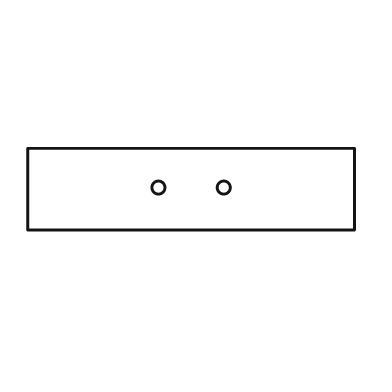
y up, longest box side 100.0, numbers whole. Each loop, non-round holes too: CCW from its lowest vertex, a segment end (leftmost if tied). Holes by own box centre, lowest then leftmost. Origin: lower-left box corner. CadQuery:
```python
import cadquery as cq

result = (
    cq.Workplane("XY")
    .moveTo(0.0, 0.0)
    .lineTo(100.0, 0.0)
    .lineTo(100.0, 25.0)
    .lineTo(0.0, 25.0)
    .close()
    .moveTo(40.0, 13.0)
    .circle(2.0)
    .moveTo(60.0, 13.0)
    .circle(2.0)
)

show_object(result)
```